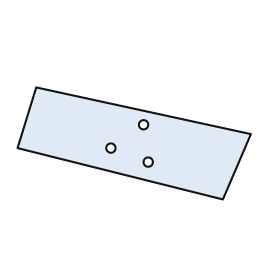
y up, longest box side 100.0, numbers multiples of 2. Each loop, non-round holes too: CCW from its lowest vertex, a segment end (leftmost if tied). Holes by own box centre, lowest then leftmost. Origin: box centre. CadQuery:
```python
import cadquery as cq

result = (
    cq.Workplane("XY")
    .moveTo(38.0, -24.0)
    .lineTo(50.0, 4.0)
    .lineTo(-42.0, 24.0)
    .lineTo(-50.0, -2.0)
    .close()
    .moveTo(6.0, -8.0)
    .circle(2.0)
    .moveTo(-10.0, -2.0)
    .circle(2.0)
    .moveTo(4.0, 8.0)
    .circle(2.0)
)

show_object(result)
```